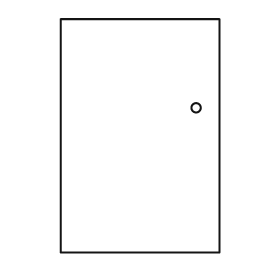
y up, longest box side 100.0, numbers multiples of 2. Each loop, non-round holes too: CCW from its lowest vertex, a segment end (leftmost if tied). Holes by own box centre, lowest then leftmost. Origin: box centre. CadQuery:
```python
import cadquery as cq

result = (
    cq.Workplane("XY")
    .moveTo(-34.0, -50.0)
    .lineTo(34.0, -50.0)
    .lineTo(34.0, 50.0)
    .lineTo(-34.0, 50.0)
    .close()
    .moveTo(24.0, 12.0)
    .circle(2.0)
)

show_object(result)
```